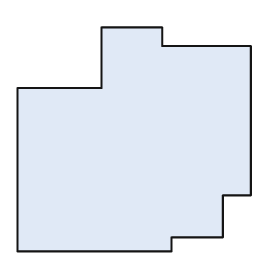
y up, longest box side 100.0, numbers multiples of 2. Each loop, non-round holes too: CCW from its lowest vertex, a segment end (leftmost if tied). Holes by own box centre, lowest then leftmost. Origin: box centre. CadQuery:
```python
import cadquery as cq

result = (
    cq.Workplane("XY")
    .moveTo(-50.0, -48.0)
    .lineTo(16.0, -48.0)
    .lineTo(16.0, -42.0)
    .lineTo(38.0, -42.0)
    .lineTo(38.0, -24.0)
    .lineTo(50.0, -24.0)
    .lineTo(50.0, 40.0)
    .lineTo(12.0, 40.0)
    .lineTo(12.0, 48.0)
    .lineTo(-14.0, 48.0)
    .lineTo(-14.0, 22.0)
    .lineTo(-50.0, 22.0)
    .close()
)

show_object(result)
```